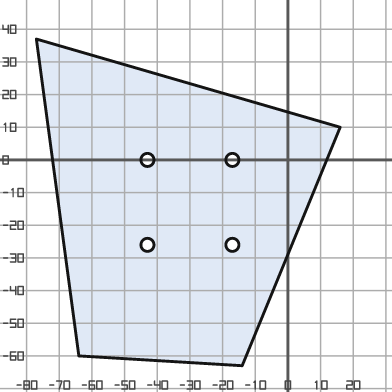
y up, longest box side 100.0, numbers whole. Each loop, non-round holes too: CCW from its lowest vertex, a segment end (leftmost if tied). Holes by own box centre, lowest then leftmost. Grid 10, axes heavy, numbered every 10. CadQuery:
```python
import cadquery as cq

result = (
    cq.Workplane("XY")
    .moveTo(-14.0, -63.0)
    .lineTo(16.0, 10.0)
    .lineTo(-77.0, 37.0)
    .lineTo(-64.0, -60.0)
    .close()
    .moveTo(-43.0, -26.0)
    .circle(2.0)
    .moveTo(-17.0, -26.0)
    .circle(2.0)
    .moveTo(-43.0, 0.0)
    .circle(2.0)
    .moveTo(-17.0, 0.0)
    .circle(2.0)
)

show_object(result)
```